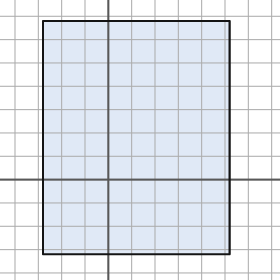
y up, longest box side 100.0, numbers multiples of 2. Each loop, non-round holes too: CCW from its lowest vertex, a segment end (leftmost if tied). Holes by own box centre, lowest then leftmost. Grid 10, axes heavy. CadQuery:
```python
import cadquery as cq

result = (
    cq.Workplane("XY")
    .moveTo(-28.0, -32.0)
    .lineTo(52.0, -32.0)
    .lineTo(52.0, 68.0)
    .lineTo(-28.0, 68.0)
    .close()
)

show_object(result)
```